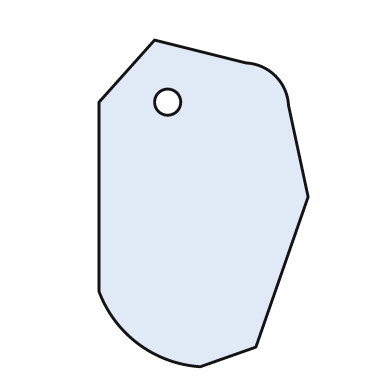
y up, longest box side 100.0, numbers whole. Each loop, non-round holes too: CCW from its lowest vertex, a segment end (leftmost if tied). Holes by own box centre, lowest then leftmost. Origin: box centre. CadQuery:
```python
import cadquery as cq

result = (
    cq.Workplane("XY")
    .moveTo(-1.0, -50.0)
    .lineTo(16.0, -44.0)
    .lineTo(32.0, 2.0)
    .lineTo(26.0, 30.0)
    .threePointArc((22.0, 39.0), (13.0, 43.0))
    .lineTo(-15.0, 50.0)
    .lineTo(-32.0, 31.0)
    .lineTo(-32.0, -27.0)
    .threePointArc((-20.0, -43.0), (-1.0, -50.0))
    .close()
    .moveTo(-11.0, 31.0)
    .circle(4.0)
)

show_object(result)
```